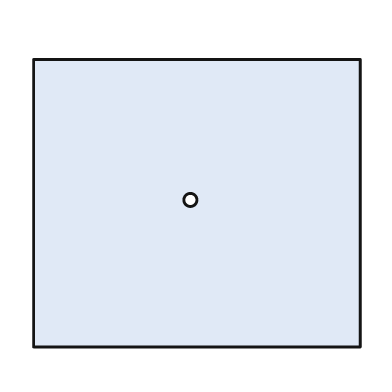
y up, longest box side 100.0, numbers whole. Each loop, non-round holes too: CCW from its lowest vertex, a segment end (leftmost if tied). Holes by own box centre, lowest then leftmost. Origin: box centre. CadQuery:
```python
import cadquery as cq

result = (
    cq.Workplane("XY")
    .moveTo(-50.0, -44.0)
    .lineTo(50.0, -44.0)
    .lineTo(50.0, 44.0)
    .lineTo(-50.0, 44.0)
    .close()
    .moveTo(-2.0, 1.0)
    .circle(2.0)
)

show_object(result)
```